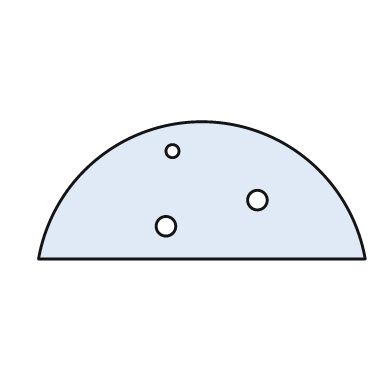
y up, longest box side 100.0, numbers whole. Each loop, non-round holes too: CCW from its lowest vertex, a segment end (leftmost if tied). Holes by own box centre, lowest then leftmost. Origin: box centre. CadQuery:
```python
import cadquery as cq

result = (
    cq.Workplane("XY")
    .moveTo(-50.0, -21.0)
    .lineTo(50.0, -21.0)
    .threePointArc((0.0, 21.0), (-50.0, -21.0))
    .close()
    .moveTo(-11.0, -11.0)
    .circle(3.0)
    .moveTo(17.0, -3.0)
    .circle(3.0)
    .moveTo(-9.0, 12.0)
    .circle(2.0)
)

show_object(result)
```